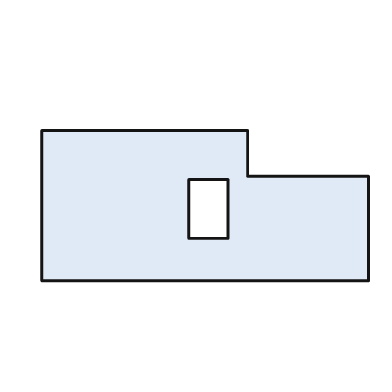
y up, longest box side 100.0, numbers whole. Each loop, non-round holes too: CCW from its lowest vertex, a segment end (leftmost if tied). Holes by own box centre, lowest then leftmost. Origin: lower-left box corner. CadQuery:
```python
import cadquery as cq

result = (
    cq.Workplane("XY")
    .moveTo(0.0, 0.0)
    .lineTo(100.0, 0.0)
    .lineTo(100.0, 32.0)
    .lineTo(63.0, 32.0)
    .lineTo(63.0, 46.0)
    .lineTo(0.0, 46.0)
    .close()
    .moveTo(45.0, 13.0)
    .lineTo(57.0, 13.0)
    .lineTo(57.0, 31.0)
    .lineTo(45.0, 31.0)
    .close()
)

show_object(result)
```